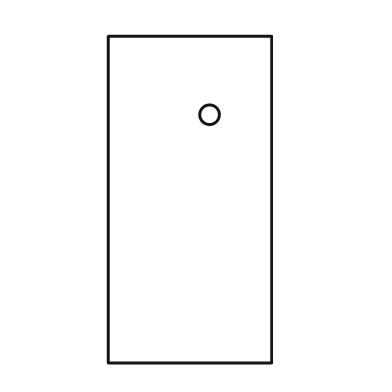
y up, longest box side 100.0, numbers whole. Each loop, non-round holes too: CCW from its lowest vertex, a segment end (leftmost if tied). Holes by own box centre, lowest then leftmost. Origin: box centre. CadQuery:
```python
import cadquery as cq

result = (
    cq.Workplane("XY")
    .moveTo(-25.0, -50.0)
    .lineTo(25.0, -50.0)
    .lineTo(25.0, 50.0)
    .lineTo(-25.0, 50.0)
    .close()
    .moveTo(6.0, 26.0)
    .circle(3.0)
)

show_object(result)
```